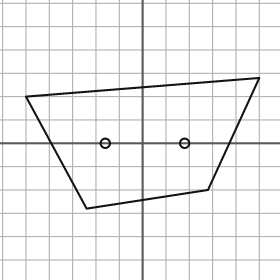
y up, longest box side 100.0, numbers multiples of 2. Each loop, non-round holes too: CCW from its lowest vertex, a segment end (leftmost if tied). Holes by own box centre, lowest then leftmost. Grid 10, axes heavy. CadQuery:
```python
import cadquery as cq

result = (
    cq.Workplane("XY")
    .moveTo(-24.0, -28.0)
    .lineTo(28.0, -20.0)
    .lineTo(50.0, 28.0)
    .lineTo(-50.0, 20.0)
    .close()
    .moveTo(-16.0, 0.0)
    .circle(2.0)
    .moveTo(18.0, 0.0)
    .circle(2.0)
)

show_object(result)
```